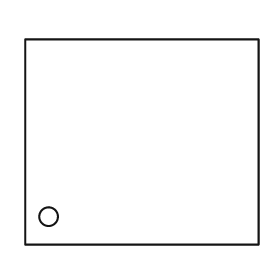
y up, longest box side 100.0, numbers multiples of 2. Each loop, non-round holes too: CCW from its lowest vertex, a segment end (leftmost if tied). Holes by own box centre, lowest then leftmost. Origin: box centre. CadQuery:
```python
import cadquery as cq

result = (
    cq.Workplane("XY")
    .moveTo(-50.0, -44.0)
    .lineTo(50.0, -44.0)
    .lineTo(50.0, 44.0)
    .lineTo(-50.0, 44.0)
    .close()
    .moveTo(-40.0, -32.0)
    .circle(4.0)
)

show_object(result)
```